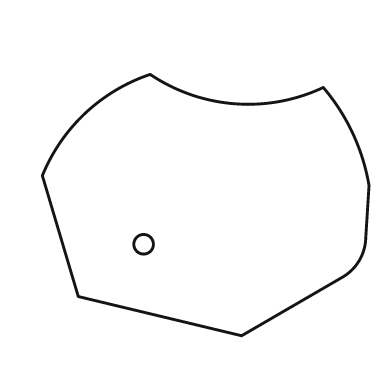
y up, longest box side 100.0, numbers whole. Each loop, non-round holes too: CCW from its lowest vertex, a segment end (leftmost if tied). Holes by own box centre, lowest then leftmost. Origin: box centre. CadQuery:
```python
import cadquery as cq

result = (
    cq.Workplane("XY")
    .moveTo(11.0, -40.0)
    .lineTo(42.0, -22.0)
    .threePointArc((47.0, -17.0), (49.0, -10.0))
    .lineTo(50.0, 6.0)
    .threePointArc((45.0, 22.0), (36.0, 36.0))
    .threePointArc((9.0, 31.0), (-17.0, 40.0))
    .threePointArc((-37.0, 28.0), (-50.0, 9.0))
    .lineTo(-39.0, -28.0)
    .close()
    .moveTo(-19.0, -12.0)
    .circle(3.0)
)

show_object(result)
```